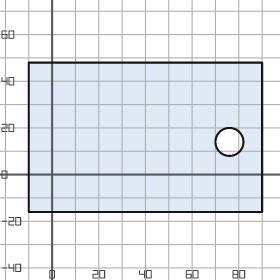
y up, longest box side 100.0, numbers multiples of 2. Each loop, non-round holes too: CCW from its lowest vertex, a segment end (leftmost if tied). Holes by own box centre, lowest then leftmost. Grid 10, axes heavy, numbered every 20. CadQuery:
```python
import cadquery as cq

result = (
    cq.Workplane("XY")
    .moveTo(-10.0, -16.0)
    .lineTo(90.0, -16.0)
    .lineTo(90.0, 48.0)
    .lineTo(-10.0, 48.0)
    .close()
    .moveTo(76.0, 14.0)
    .circle(6.0)
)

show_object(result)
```